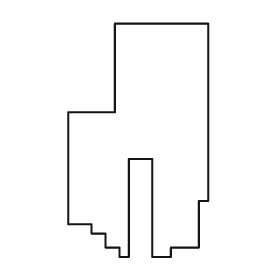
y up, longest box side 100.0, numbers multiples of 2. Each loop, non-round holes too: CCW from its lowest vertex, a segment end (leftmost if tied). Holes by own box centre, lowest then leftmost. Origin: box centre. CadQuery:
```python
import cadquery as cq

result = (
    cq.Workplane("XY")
    .moveTo(-8.0, -50.0)
    .lineTo(-4.0, -50.0)
    .lineTo(-4.0, -8.0)
    .lineTo(6.0, -8.0)
    .lineTo(6.0, -50.0)
    .lineTo(14.0, -50.0)
    .lineTo(14.0, -46.0)
    .lineTo(26.0, -46.0)
    .lineTo(26.0, -26.0)
    .lineTo(30.0, -26.0)
    .lineTo(30.0, 50.0)
    .lineTo(-10.0, 50.0)
    .lineTo(-10.0, 12.0)
    .lineTo(-30.0, 12.0)
    .lineTo(-30.0, -36.0)
    .lineTo(-20.0, -36.0)
    .lineTo(-20.0, -40.0)
    .lineTo(-14.0, -40.0)
    .lineTo(-14.0, -46.0)
    .lineTo(-8.0, -46.0)
    .close()
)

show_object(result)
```